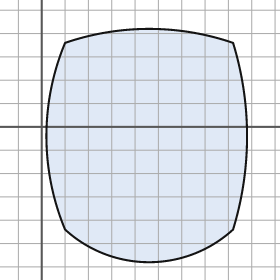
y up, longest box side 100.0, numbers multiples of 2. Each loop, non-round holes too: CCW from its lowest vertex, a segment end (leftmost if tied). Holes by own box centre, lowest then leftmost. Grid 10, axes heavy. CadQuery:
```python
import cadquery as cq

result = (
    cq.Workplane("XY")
    .moveTo(10.0, -44.0)
    .threePointArc((46.0, -58.0), (82.0, -44.0))
    .threePointArc((88.0, -4.0), (82.0, 36.0))
    .threePointArc((46.0, 42.0), (10.0, 36.0))
    .threePointArc((2.0, -4.0), (10.0, -44.0))
    .close()
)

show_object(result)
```